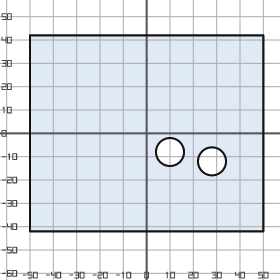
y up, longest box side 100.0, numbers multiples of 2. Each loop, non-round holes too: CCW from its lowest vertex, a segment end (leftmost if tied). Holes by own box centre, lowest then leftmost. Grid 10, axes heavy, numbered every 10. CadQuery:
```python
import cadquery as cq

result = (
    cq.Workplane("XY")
    .moveTo(-50.0, -42.0)
    .lineTo(50.0, -42.0)
    .lineTo(50.0, 42.0)
    .lineTo(-50.0, 42.0)
    .close()
    .moveTo(28.0, -12.0)
    .circle(6.0)
    .moveTo(10.0, -8.0)
    .circle(6.0)
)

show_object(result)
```